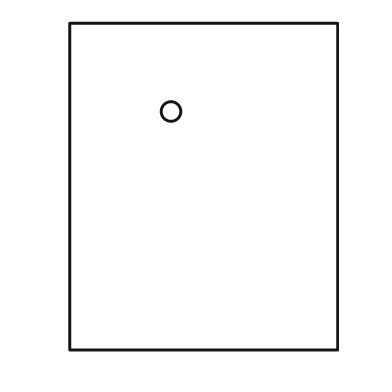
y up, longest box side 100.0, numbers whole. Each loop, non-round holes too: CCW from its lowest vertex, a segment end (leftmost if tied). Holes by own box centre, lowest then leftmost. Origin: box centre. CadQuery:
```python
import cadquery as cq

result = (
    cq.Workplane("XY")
    .moveTo(-41.0, -50.0)
    .lineTo(41.0, -50.0)
    .lineTo(41.0, 50.0)
    .lineTo(-41.0, 50.0)
    .close()
    .moveTo(-10.0, 23.0)
    .circle(3.0)
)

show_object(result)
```